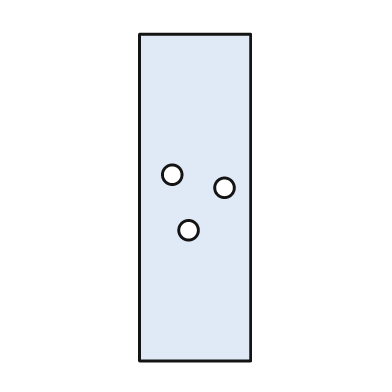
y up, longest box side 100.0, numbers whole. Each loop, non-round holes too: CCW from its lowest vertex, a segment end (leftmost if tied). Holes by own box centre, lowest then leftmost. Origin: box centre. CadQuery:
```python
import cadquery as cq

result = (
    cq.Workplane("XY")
    .moveTo(-17.0, -50.0)
    .lineTo(17.0, -50.0)
    .lineTo(17.0, 50.0)
    .lineTo(-17.0, 50.0)
    .close()
    .moveTo(-2.0, -10.0)
    .circle(3.0)
    .moveTo(9.0, 3.0)
    .circle(3.0)
    .moveTo(-7.0, 7.0)
    .circle(3.0)
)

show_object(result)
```